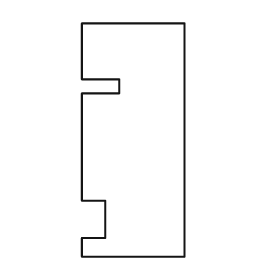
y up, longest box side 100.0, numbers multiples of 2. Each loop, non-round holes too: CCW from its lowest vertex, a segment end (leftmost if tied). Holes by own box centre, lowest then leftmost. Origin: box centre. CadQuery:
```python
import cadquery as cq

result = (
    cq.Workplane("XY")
    .moveTo(-22.0, -50.0)
    .lineTo(22.0, -50.0)
    .lineTo(22.0, 50.0)
    .lineTo(-22.0, 50.0)
    .lineTo(-22.0, 26.0)
    .lineTo(-6.0, 26.0)
    .lineTo(-6.0, 20.0)
    .lineTo(-22.0, 20.0)
    .lineTo(-22.0, -26.0)
    .lineTo(-12.0, -26.0)
    .lineTo(-12.0, -42.0)
    .lineTo(-22.0, -42.0)
    .close()
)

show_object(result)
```